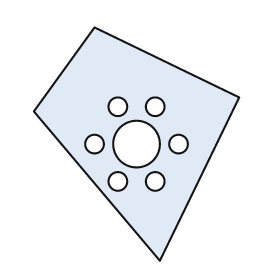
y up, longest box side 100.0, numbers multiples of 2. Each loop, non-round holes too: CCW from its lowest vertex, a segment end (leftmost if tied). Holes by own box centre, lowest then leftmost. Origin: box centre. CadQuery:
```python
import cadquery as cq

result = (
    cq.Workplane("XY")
    .moveTo(10.0, -50.0)
    .lineTo(44.0, 20.0)
    .lineTo(-18.0, 50.0)
    .lineTo(-44.0, 14.0)
    .close()
    .moveTo(-8.0, -16.0)
    .circle(4.0)
    .moveTo(8.0, -16.0)
    .circle(4.0)
    .moveTo(-18.0, 0.0)
    .circle(4.0)
    .moveTo(0.0, 0.0)
    .circle(10.0)
    .moveTo(18.0, 0.0)
    .circle(4.0)
    .moveTo(-8.0, 16.0)
    .circle(4.0)
    .moveTo(8.0, 16.0)
    .circle(4.0)
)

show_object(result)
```